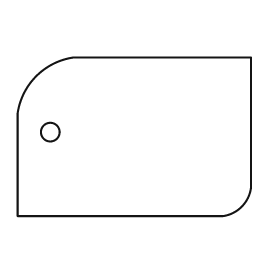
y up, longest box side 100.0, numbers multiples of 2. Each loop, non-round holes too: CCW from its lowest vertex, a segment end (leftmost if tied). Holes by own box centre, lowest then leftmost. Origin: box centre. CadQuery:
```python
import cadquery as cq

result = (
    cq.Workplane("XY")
    .moveTo(-50.0, -34.0)
    .lineTo(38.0, -34.0)
    .threePointArc((46.0, -30.0), (50.0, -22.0))
    .lineTo(50.0, 34.0)
    .lineTo(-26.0, 34.0)
    .threePointArc((-42.0, 26.0), (-50.0, 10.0))
    .close()
    .moveTo(-36.0, 2.0)
    .circle(4.0)
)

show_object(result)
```